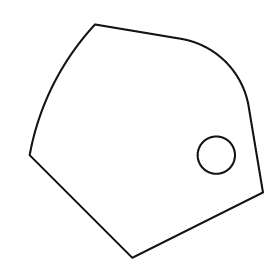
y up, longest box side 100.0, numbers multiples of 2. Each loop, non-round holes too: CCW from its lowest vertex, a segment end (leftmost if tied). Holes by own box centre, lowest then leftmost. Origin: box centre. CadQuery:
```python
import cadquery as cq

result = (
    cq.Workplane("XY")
    .moveTo(-6.0, -50.0)
    .lineTo(50.0, -22.0)
    .lineTo(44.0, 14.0)
    .threePointArc((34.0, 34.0), (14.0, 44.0))
    .lineTo(-22.0, 50.0)
    .threePointArc((-40.0, 24.0), (-50.0, -6.0))
    .close()
    .moveTo(30.0, -6.0)
    .circle(8.0)
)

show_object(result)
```